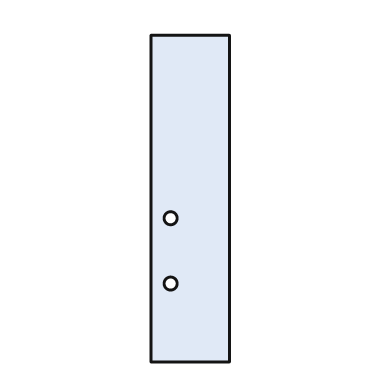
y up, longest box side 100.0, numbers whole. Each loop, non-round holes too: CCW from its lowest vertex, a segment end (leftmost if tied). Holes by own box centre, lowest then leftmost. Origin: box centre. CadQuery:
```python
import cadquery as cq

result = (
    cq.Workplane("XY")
    .moveTo(-12.0, -50.0)
    .lineTo(12.0, -50.0)
    .lineTo(12.0, 50.0)
    .lineTo(-12.0, 50.0)
    .close()
    .moveTo(-6.0, -26.0)
    .circle(2.0)
    .moveTo(-6.0, -6.0)
    .circle(2.0)
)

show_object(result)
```